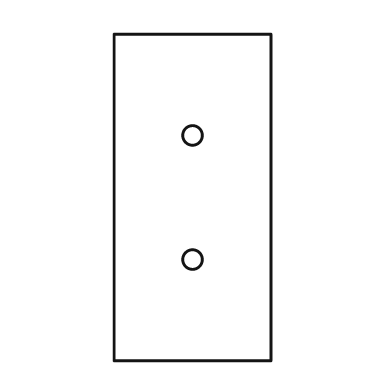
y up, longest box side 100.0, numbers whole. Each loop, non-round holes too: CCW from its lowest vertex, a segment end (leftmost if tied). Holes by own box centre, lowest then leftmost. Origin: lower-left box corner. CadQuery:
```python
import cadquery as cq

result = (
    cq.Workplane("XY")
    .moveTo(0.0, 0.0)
    .lineTo(48.0, 0.0)
    .lineTo(48.0, 100.0)
    .lineTo(0.0, 100.0)
    .close()
    .moveTo(24.0, 31.0)
    .circle(3.0)
    .moveTo(24.0, 69.0)
    .circle(3.0)
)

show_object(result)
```